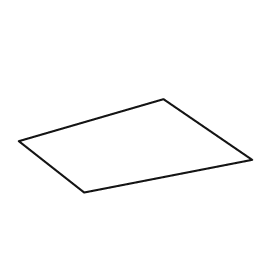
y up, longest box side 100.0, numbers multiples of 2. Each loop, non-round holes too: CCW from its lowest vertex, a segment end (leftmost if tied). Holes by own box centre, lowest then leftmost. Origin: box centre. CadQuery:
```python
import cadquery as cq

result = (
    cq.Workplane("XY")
    .moveTo(-22.0, -20.0)
    .lineTo(50.0, -6.0)
    .lineTo(12.0, 20.0)
    .lineTo(-50.0, 2.0)
    .close()
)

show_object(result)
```